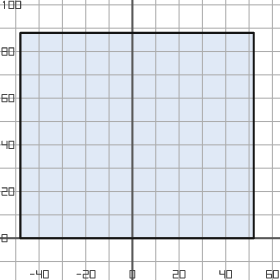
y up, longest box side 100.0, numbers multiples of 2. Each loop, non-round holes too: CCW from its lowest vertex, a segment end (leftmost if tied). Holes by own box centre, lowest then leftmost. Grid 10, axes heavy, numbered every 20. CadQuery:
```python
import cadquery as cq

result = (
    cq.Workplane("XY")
    .moveTo(-48.0, 0.0)
    .lineTo(52.0, 0.0)
    .lineTo(52.0, 88.0)
    .lineTo(-48.0, 88.0)
    .close()
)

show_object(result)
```